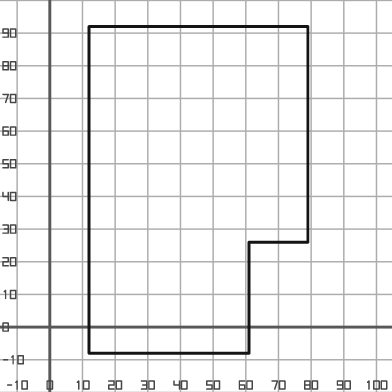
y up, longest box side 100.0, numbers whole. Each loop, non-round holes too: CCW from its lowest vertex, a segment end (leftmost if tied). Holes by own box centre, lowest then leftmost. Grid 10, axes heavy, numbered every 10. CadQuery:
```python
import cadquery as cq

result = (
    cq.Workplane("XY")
    .moveTo(12.0, -8.0)
    .lineTo(61.0, -8.0)
    .lineTo(61.0, 26.0)
    .lineTo(79.0, 26.0)
    .lineTo(79.0, 92.0)
    .lineTo(12.0, 92.0)
    .close()
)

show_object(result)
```